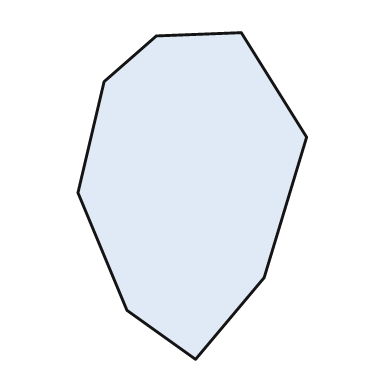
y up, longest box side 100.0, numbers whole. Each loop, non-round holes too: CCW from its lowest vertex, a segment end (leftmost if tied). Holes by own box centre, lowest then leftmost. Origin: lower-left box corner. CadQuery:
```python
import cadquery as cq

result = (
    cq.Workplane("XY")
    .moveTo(36.0, 0.0)
    .lineTo(57.0, 25.0)
    .lineTo(70.0, 68.0)
    .lineTo(50.0, 100.0)
    .lineTo(24.0, 99.0)
    .lineTo(8.0, 85.0)
    .lineTo(0.0, 51.0)
    .lineTo(15.0, 15.0)
    .close()
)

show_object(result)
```